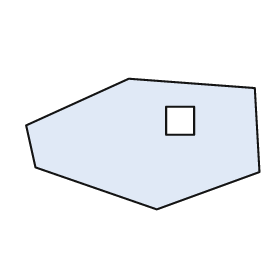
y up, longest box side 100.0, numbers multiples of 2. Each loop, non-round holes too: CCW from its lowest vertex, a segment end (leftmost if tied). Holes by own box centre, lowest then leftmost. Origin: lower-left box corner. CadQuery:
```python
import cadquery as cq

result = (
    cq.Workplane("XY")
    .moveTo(56.0, 0.0)
    .lineTo(100.0, 16.0)
    .lineTo(98.0, 52.0)
    .lineTo(44.0, 56.0)
    .lineTo(0.0, 36.0)
    .lineTo(4.0, 18.0)
    .close()
    .moveTo(60.0, 32.0)
    .lineTo(72.0, 32.0)
    .lineTo(72.0, 44.0)
    .lineTo(60.0, 44.0)
    .close()
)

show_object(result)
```